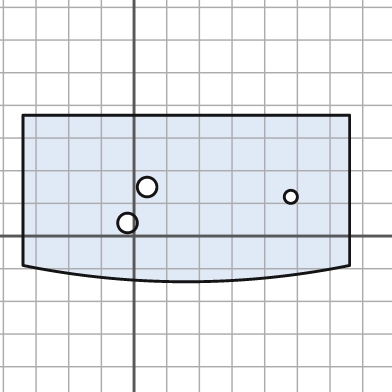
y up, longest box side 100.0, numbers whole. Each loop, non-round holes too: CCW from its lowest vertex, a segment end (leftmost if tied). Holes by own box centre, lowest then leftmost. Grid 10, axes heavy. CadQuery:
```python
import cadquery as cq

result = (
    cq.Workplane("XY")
    .moveTo(-34.0, -9.0)
    .threePointArc((16.0, -14.0), (66.0, -9.0))
    .lineTo(66.0, 37.0)
    .lineTo(-34.0, 37.0)
    .close()
    .moveTo(-2.0, 4.0)
    .circle(3.0)
    .moveTo(48.0, 12.0)
    .circle(2.0)
    .moveTo(4.0, 15.0)
    .circle(3.0)
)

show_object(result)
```